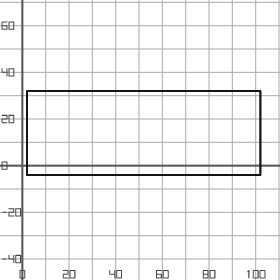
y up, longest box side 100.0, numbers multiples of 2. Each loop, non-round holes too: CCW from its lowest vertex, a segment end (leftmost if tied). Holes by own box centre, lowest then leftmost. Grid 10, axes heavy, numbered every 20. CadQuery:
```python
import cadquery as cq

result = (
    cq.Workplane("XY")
    .moveTo(2.0, -4.0)
    .lineTo(102.0, -4.0)
    .lineTo(102.0, 32.0)
    .lineTo(2.0, 32.0)
    .close()
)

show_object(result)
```